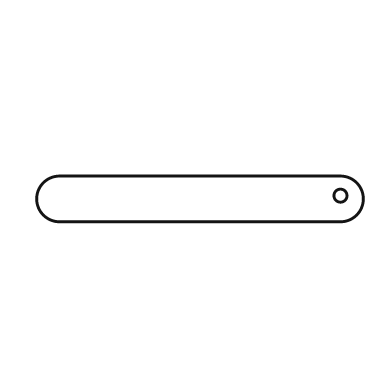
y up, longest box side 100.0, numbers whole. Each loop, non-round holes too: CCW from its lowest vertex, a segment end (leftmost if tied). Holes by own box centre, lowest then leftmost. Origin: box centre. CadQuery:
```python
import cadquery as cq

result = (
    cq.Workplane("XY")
    .moveTo(-43.0, -7.0)
    .lineTo(43.0, -7.0)
    .threePointArc((50.0, 0.0), (43.0, 7.0))
    .lineTo(-43.0, 7.0)
    .threePointArc((-50.0, 0.0), (-43.0, -7.0))
    .close()
    .moveTo(43.0, 1.0)
    .circle(2.0)
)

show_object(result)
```